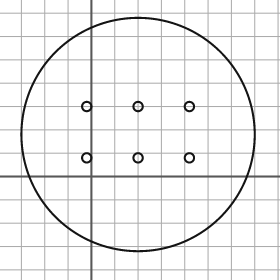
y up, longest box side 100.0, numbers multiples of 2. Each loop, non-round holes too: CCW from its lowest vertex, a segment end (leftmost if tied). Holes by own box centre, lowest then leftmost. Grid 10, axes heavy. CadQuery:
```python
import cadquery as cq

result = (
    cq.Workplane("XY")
    .moveTo(20.0, 18.0)
    .circle(50.0)
    .moveTo(-2.0, 8.0)
    .circle(2.0)
    .moveTo(20.0, 8.0)
    .circle(2.0)
    .moveTo(42.0, 8.0)
    .circle(2.0)
    .moveTo(-2.0, 30.0)
    .circle(2.0)
    .moveTo(20.0, 30.0)
    .circle(2.0)
    .moveTo(42.0, 30.0)
    .circle(2.0)
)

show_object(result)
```